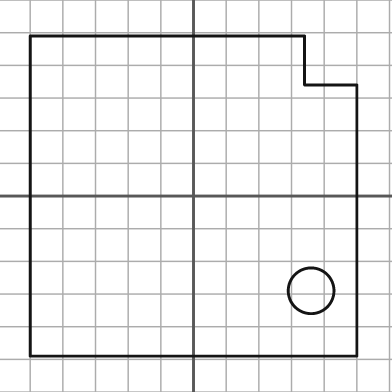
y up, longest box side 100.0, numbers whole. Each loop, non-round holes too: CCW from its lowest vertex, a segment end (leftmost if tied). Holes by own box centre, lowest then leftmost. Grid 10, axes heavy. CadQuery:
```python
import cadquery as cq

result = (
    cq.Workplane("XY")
    .moveTo(-50.0, -49.0)
    .lineTo(50.0, -49.0)
    .lineTo(50.0, 34.0)
    .lineTo(34.0, 34.0)
    .lineTo(34.0, 49.0)
    .lineTo(-50.0, 49.0)
    .close()
    .moveTo(36.0, -29.0)
    .circle(7.0)
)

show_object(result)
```